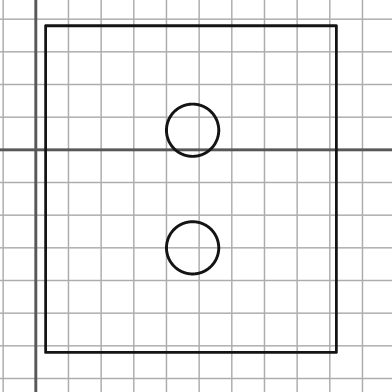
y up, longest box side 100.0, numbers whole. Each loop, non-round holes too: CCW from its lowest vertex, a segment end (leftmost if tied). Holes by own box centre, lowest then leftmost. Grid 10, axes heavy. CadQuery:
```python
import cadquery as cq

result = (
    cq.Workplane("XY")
    .moveTo(3.0, -62.0)
    .lineTo(92.0, -62.0)
    .lineTo(92.0, 38.0)
    .lineTo(3.0, 38.0)
    .close()
    .moveTo(48.0, -30.0)
    .circle(8.0)
    .moveTo(48.0, 6.0)
    .circle(8.0)
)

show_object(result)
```